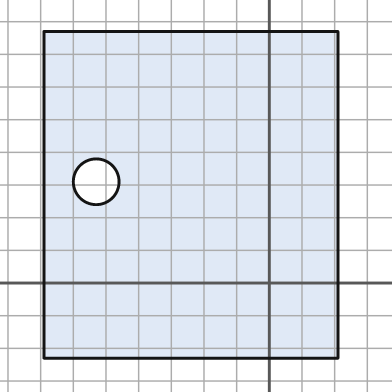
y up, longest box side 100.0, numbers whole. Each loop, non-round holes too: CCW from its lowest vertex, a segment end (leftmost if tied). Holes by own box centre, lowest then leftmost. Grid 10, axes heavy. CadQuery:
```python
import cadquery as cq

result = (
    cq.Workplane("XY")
    .moveTo(-69.0, -23.0)
    .lineTo(21.0, -23.0)
    .lineTo(21.0, 77.0)
    .lineTo(-69.0, 77.0)
    .close()
    .moveTo(-53.0, 31.0)
    .circle(7.0)
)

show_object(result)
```